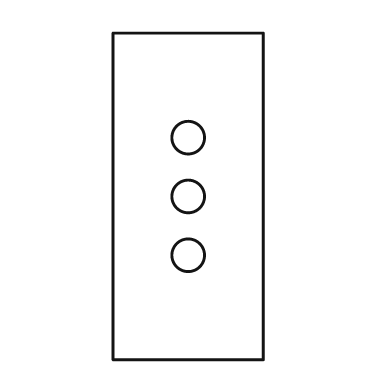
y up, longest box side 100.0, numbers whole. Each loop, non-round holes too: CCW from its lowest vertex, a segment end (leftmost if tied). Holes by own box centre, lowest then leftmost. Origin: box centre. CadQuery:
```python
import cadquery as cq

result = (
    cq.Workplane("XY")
    .moveTo(-23.0, -50.0)
    .lineTo(23.0, -50.0)
    .lineTo(23.0, 50.0)
    .lineTo(-23.0, 50.0)
    .close()
    .moveTo(0.0, -18.0)
    .circle(5.0)
    .moveTo(0.0, 0.0)
    .circle(5.0)
    .moveTo(0.0, 18.0)
    .circle(5.0)
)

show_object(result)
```